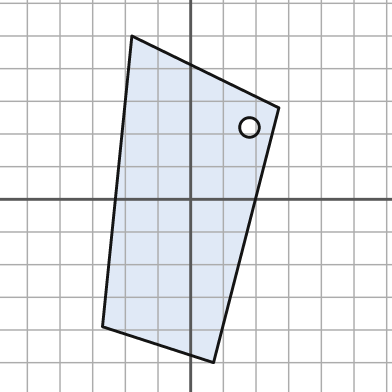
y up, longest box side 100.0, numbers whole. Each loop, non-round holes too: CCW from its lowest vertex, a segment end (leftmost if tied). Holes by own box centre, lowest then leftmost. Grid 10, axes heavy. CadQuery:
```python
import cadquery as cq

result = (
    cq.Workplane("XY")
    .moveTo(7.0, -50.0)
    .lineTo(27.0, 28.0)
    .lineTo(-18.0, 50.0)
    .lineTo(-27.0, -39.0)
    .close()
    .moveTo(18.0, 22.0)
    .circle(3.0)
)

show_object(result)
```